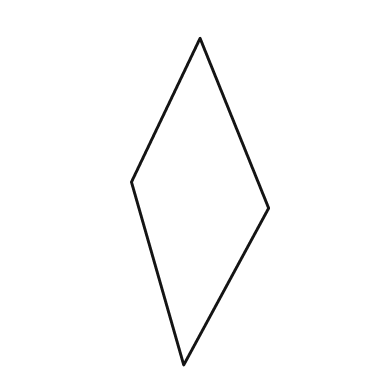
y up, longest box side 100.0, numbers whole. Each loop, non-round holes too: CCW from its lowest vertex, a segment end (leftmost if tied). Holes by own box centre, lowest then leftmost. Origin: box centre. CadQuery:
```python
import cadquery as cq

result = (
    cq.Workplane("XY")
    .moveTo(-5.0, -50.0)
    .lineTo(21.0, -2.0)
    .lineTo(0.0, 50.0)
    .lineTo(-21.0, 6.0)
    .close()
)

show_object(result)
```